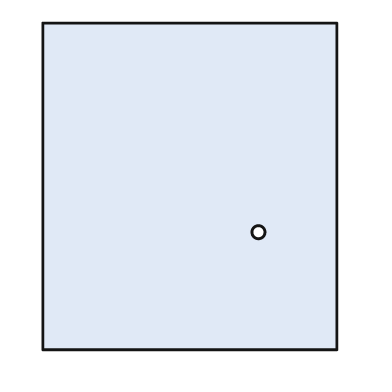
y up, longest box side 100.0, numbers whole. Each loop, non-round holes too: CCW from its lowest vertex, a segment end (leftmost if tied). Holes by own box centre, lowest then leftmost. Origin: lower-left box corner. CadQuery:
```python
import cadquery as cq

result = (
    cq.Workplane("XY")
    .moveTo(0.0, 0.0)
    .lineTo(90.0, 0.0)
    .lineTo(90.0, 100.0)
    .lineTo(0.0, 100.0)
    .close()
    .moveTo(66.0, 36.0)
    .circle(2.0)
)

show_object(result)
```